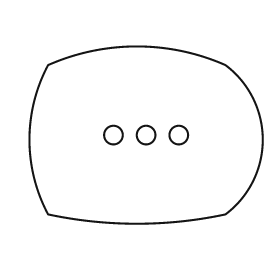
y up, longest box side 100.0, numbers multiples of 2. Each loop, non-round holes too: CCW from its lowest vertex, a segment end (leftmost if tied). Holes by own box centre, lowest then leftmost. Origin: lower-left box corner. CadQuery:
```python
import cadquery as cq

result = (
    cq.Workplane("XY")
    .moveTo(8.0, 4.0)
    .threePointArc((46.0, 0.0), (84.0, 4.0))
    .threePointArc((100.0, 36.0), (84.0, 68.0))
    .threePointArc((46.0, 76.0), (8.0, 68.0))
    .threePointArc((0.0, 36.0), (8.0, 4.0))
    .close()
    .moveTo(36.0, 38.0)
    .circle(4.0)
    .moveTo(50.0, 38.0)
    .circle(4.0)
    .moveTo(64.0, 38.0)
    .circle(4.0)
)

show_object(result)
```